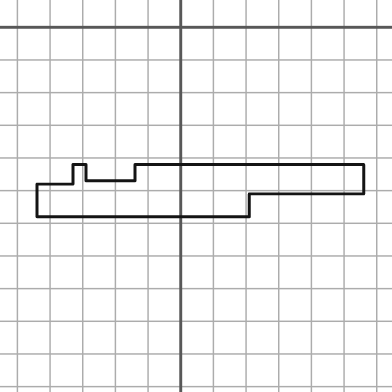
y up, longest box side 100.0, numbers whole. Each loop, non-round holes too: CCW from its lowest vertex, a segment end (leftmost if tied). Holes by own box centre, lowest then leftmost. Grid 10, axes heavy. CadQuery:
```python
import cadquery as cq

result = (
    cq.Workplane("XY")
    .moveTo(-44.0, -58.0)
    .lineTo(21.0, -58.0)
    .lineTo(21.0, -51.0)
    .lineTo(56.0, -51.0)
    .lineTo(56.0, -42.0)
    .lineTo(-14.0, -42.0)
    .lineTo(-14.0, -47.0)
    .lineTo(-29.0, -47.0)
    .lineTo(-29.0, -42.0)
    .lineTo(-33.0, -42.0)
    .lineTo(-33.0, -48.0)
    .lineTo(-44.0, -48.0)
    .close()
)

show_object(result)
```